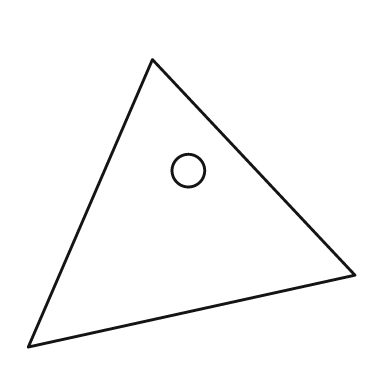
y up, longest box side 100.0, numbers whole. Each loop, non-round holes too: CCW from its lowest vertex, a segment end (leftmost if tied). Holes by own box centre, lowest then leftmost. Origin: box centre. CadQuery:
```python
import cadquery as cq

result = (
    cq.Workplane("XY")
    .moveTo(-50.0, -44.0)
    .lineTo(50.0, -22.0)
    .lineTo(-12.0, 44.0)
    .close()
    .moveTo(-1.0, 10.0)
    .circle(5.0)
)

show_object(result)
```